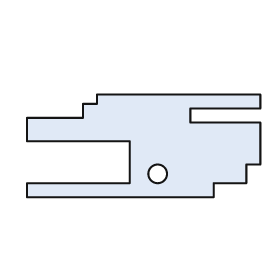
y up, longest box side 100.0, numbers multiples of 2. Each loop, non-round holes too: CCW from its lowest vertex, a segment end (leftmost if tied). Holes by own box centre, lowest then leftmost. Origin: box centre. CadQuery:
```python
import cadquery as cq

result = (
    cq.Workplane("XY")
    .moveTo(-50.0, -22.0)
    .lineTo(30.0, -22.0)
    .lineTo(30.0, -16.0)
    .lineTo(44.0, -16.0)
    .lineTo(44.0, -8.0)
    .lineTo(50.0, -8.0)
    .lineTo(50.0, 10.0)
    .lineTo(20.0, 10.0)
    .lineTo(20.0, 16.0)
    .lineTo(50.0, 16.0)
    .lineTo(50.0, 22.0)
    .lineTo(-20.0, 22.0)
    .lineTo(-20.0, 18.0)
    .lineTo(-26.0, 18.0)
    .lineTo(-26.0, 12.0)
    .lineTo(-50.0, 12.0)
    .lineTo(-50.0, 2.0)
    .lineTo(-6.0, 2.0)
    .lineTo(-6.0, -16.0)
    .lineTo(-50.0, -16.0)
    .close()
    .moveTo(6.0, -12.0)
    .circle(4.0)
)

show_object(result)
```